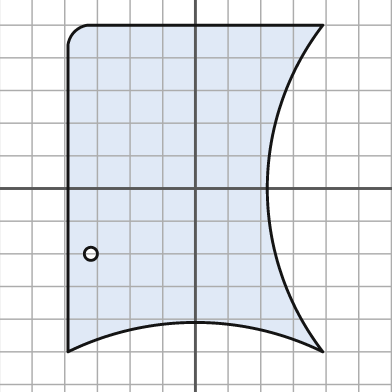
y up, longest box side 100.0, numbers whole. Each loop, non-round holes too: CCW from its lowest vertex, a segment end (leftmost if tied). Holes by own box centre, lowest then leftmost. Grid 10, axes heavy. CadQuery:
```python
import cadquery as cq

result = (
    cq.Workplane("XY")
    .moveTo(-39.0, -50.0)
    .threePointArc((0.0, -41.0), (39.0, -50.0))
    .threePointArc((22.0, 0.0), (39.0, 50.0))
    .lineTo(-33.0, 50.0)
    .threePointArc((-37.0, 48.0), (-39.0, 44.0))
    .close()
    .moveTo(-32.0, -20.0)
    .circle(2.0)
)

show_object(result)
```